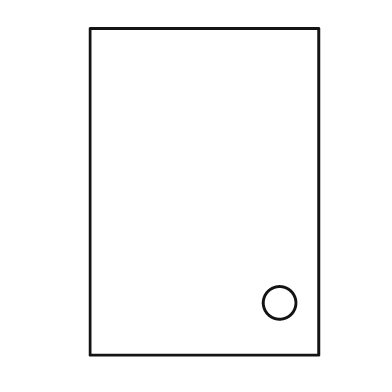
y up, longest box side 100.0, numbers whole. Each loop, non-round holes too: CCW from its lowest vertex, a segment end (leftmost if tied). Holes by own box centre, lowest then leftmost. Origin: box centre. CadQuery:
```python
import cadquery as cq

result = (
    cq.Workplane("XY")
    .moveTo(-35.0, -50.0)
    .lineTo(35.0, -50.0)
    .lineTo(35.0, 50.0)
    .lineTo(-35.0, 50.0)
    .close()
    .moveTo(23.0, -34.0)
    .circle(5.0)
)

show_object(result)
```